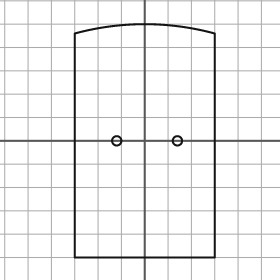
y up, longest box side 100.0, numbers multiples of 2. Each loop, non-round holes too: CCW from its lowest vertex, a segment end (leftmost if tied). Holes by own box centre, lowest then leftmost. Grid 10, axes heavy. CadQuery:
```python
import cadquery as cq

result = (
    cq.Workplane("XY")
    .moveTo(-30.0, -50.0)
    .lineTo(30.0, -50.0)
    .lineTo(30.0, 46.0)
    .threePointArc((0.0, 50.0), (-30.0, 46.0))
    .close()
    .moveTo(-12.0, 0.0)
    .circle(2.0)
    .moveTo(14.0, 0.0)
    .circle(2.0)
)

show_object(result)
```